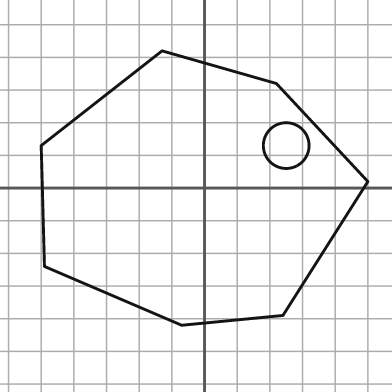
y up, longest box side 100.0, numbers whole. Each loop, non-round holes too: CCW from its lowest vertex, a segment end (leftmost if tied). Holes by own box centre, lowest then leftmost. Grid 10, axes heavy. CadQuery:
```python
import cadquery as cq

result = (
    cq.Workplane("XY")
    .moveTo(-7.0, -42.0)
    .lineTo(24.0, -39.0)
    .lineTo(50.0, 2.0)
    .lineTo(22.0, 32.0)
    .lineTo(-13.0, 42.0)
    .lineTo(-50.0, 13.0)
    .lineTo(-49.0, -24.0)
    .close()
    .moveTo(25.0, 13.0)
    .circle(7.0)
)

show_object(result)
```